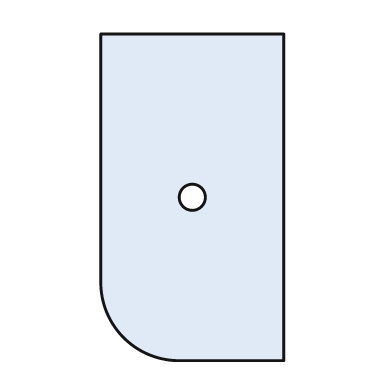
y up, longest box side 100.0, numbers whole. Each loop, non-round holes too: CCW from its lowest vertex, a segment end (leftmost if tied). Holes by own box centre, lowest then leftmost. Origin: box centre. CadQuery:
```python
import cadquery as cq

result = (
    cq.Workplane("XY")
    .moveTo(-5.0, -50.0)
    .lineTo(28.0, -50.0)
    .lineTo(28.0, 50.0)
    .lineTo(-28.0, 50.0)
    .lineTo(-28.0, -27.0)
    .threePointArc((-21.0, -43.0), (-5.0, -50.0))
    .close()
    .moveTo(0.0, 0.0)
    .circle(4.0)
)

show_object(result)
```